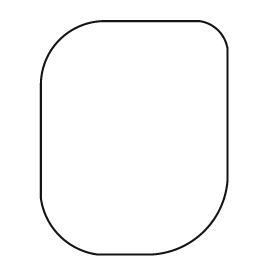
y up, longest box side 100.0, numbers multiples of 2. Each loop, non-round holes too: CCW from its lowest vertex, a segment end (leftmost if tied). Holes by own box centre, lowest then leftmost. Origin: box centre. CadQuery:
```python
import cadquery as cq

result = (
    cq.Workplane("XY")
    .moveTo(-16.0, -50.0)
    .lineTo(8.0, -50.0)
    .threePointArc((30.0, -40.0), (40.0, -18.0))
    .lineTo(40.0, 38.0)
    .threePointArc((36.0, 46.0), (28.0, 50.0))
    .lineTo(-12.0, 50.0)
    .threePointArc((-32.0, 42.0), (-40.0, 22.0))
    .lineTo(-40.0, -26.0)
    .threePointArc((-32.0, -42.0), (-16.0, -50.0))
    .close()
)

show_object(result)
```